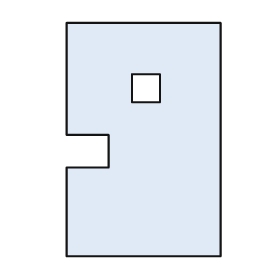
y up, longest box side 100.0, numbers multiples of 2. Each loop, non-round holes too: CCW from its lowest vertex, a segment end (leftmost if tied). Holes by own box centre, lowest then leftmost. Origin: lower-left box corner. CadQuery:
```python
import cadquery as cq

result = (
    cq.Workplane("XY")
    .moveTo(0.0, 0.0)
    .lineTo(66.0, 0.0)
    .lineTo(66.0, 100.0)
    .lineTo(0.0, 100.0)
    .lineTo(0.0, 52.0)
    .lineTo(18.0, 52.0)
    .lineTo(18.0, 38.0)
    .lineTo(0.0, 38.0)
    .close()
    .moveTo(28.0, 66.0)
    .lineTo(40.0, 66.0)
    .lineTo(40.0, 78.0)
    .lineTo(28.0, 78.0)
    .close()
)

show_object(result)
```